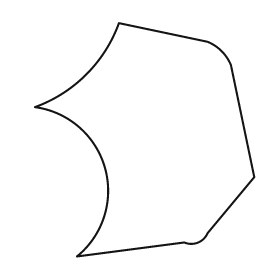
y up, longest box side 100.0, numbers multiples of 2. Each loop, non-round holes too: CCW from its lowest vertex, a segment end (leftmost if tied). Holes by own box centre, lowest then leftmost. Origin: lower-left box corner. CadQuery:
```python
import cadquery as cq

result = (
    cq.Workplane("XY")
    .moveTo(18.0, 0.0)
    .lineTo(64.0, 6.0)
    .threePointArc((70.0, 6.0), (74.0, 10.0))
    .lineTo(94.0, 34.0)
    .lineTo(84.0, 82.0)
    .threePointArc((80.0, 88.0), (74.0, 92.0))
    .lineTo(36.0, 100.0)
    .threePointArc((22.0, 78.0), (0.0, 64.0))
    .threePointArc((30.0, 38.0), (18.0, 0.0))
    .close()
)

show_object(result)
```